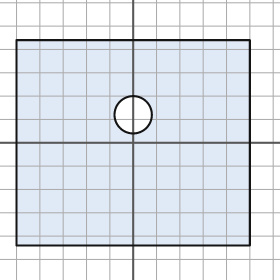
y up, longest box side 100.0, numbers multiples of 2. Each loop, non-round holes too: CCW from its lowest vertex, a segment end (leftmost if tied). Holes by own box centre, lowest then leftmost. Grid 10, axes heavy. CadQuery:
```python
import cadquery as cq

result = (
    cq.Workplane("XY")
    .moveTo(-50.0, -44.0)
    .lineTo(50.0, -44.0)
    .lineTo(50.0, 44.0)
    .lineTo(-50.0, 44.0)
    .close()
    .moveTo(0.0, 12.0)
    .circle(8.0)
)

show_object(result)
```